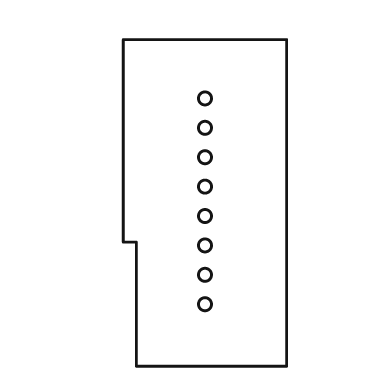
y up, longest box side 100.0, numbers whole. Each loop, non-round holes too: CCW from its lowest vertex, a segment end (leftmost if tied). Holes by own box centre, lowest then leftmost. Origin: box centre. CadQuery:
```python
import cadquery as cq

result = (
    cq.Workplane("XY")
    .moveTo(-21.0, -50.0)
    .lineTo(25.0, -50.0)
    .lineTo(25.0, 50.0)
    .lineTo(-25.0, 50.0)
    .lineTo(-25.0, -12.0)
    .lineTo(-21.0, -12.0)
    .close()
    .moveTo(0.0, -31.0)
    .circle(2.0)
    .moveTo(0.0, -22.0)
    .circle(2.0)
    .moveTo(0.0, -13.0)
    .circle(2.0)
    .moveTo(0.0, -4.0)
    .circle(2.0)
    .moveTo(0.0, 5.0)
    .circle(2.0)
    .moveTo(0.0, 14.0)
    .circle(2.0)
    .moveTo(0.0, 23.0)
    .circle(2.0)
    .moveTo(0.0, 32.0)
    .circle(2.0)
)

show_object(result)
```